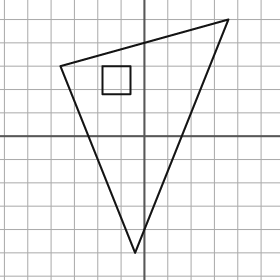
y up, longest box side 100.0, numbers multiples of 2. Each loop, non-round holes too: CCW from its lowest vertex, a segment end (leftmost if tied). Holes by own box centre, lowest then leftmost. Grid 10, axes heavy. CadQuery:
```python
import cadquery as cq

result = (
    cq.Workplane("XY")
    .moveTo(-4.0, -50.0)
    .lineTo(36.0, 50.0)
    .lineTo(-36.0, 30.0)
    .close()
    .moveTo(-18.0, 18.0)
    .lineTo(-6.0, 18.0)
    .lineTo(-6.0, 30.0)
    .lineTo(-18.0, 30.0)
    .close()
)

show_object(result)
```